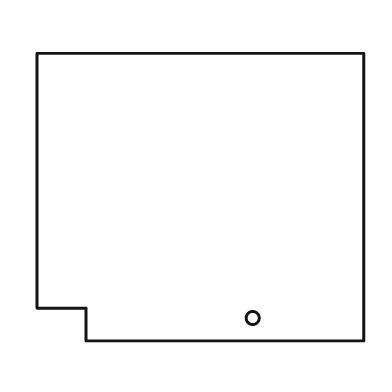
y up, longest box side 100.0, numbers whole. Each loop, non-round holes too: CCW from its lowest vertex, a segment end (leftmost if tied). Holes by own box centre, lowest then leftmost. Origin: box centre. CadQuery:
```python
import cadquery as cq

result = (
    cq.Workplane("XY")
    .moveTo(-35.0, -44.0)
    .lineTo(50.0, -44.0)
    .lineTo(50.0, 44.0)
    .lineTo(-50.0, 44.0)
    .lineTo(-50.0, -34.0)
    .lineTo(-35.0, -34.0)
    .close()
    .moveTo(16.0, -37.0)
    .circle(2.0)
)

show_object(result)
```